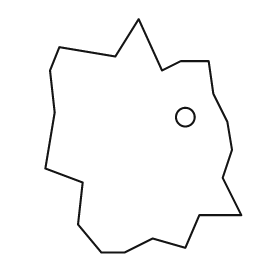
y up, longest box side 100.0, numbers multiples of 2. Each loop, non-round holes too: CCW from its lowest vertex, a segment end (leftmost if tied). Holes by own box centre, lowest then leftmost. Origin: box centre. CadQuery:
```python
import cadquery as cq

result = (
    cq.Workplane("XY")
    .moveTo(-18.0, -50.0)
    .lineTo(-8.0, -50.0)
    .lineTo(4.0, -44.0)
    .lineTo(18.0, -48.0)
    .lineTo(24.0, -34.0)
    .lineTo(42.0, -34.0)
    .lineTo(34.0, -18.0)
    .lineTo(38.0, -6.0)
    .lineTo(36.0, 6.0)
    .lineTo(30.0, 18.0)
    .lineTo(28.0, 32.0)
    .lineTo(16.0, 32.0)
    .lineTo(8.0, 28.0)
    .lineTo(-2.0, 50.0)
    .lineTo(-12.0, 34.0)
    .lineTo(-36.0, 38.0)
    .lineTo(-40.0, 28.0)
    .lineTo(-38.0, 10.0)
    .lineTo(-42.0, -14.0)
    .lineTo(-26.0, -20.0)
    .lineTo(-28.0, -38.0)
    .close()
    .moveTo(18.0, 8.0)
    .circle(4.0)
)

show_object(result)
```